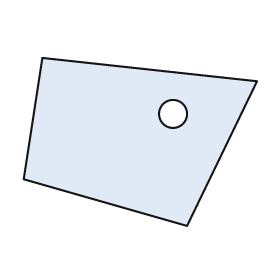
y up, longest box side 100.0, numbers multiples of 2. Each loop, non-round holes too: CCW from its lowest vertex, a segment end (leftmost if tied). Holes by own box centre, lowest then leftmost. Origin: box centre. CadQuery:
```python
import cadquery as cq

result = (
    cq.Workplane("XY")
    .moveTo(20.0, -36.0)
    .lineTo(50.0, 26.0)
    .lineTo(-42.0, 36.0)
    .lineTo(-50.0, -16.0)
    .close()
    .moveTo(14.0, 12.0)
    .circle(6.0)
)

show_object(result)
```